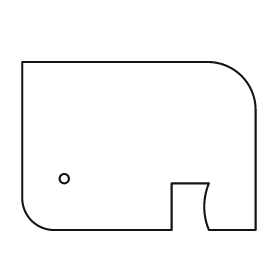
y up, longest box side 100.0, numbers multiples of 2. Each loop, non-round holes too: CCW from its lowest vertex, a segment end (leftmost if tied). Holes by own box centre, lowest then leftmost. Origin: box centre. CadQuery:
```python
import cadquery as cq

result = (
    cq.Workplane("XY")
    .moveTo(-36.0, -36.0)
    .lineTo(14.0, -36.0)
    .lineTo(14.0, -16.0)
    .lineTo(30.0, -16.0)
    .threePointArc((28.0, -26.0), (30.0, -36.0))
    .lineTo(50.0, -36.0)
    .lineTo(50.0, 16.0)
    .threePointArc((44.0, 30.0), (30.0, 36.0))
    .lineTo(-50.0, 36.0)
    .lineTo(-50.0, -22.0)
    .threePointArc((-46.0, -32.0), (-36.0, -36.0))
    .close()
    .moveTo(-32.0, -14.0)
    .circle(2.0)
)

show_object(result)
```